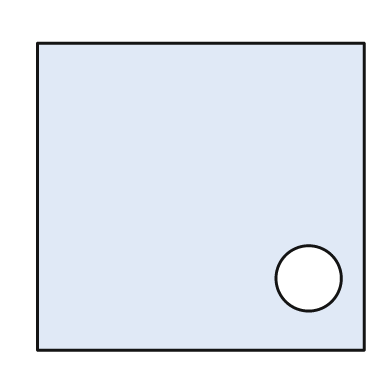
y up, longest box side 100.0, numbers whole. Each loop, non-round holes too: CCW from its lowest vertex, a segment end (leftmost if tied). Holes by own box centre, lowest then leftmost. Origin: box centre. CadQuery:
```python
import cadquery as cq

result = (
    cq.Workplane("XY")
    .moveTo(-50.0, -47.0)
    .lineTo(50.0, -47.0)
    .lineTo(50.0, 47.0)
    .lineTo(-50.0, 47.0)
    .close()
    .moveTo(33.0, -25.0)
    .circle(10.0)
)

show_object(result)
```